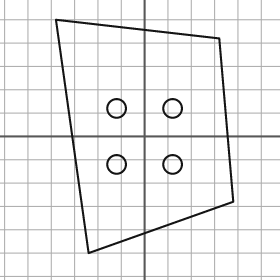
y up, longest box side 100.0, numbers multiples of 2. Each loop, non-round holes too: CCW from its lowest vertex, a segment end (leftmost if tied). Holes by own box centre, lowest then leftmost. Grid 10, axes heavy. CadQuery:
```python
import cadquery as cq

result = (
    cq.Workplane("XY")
    .moveTo(-24.0, -50.0)
    .lineTo(38.0, -28.0)
    .lineTo(32.0, 42.0)
    .lineTo(-38.0, 50.0)
    .close()
    .moveTo(-12.0, -12.0)
    .circle(4.0)
    .moveTo(12.0, -12.0)
    .circle(4.0)
    .moveTo(-12.0, 12.0)
    .circle(4.0)
    .moveTo(12.0, 12.0)
    .circle(4.0)
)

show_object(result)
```